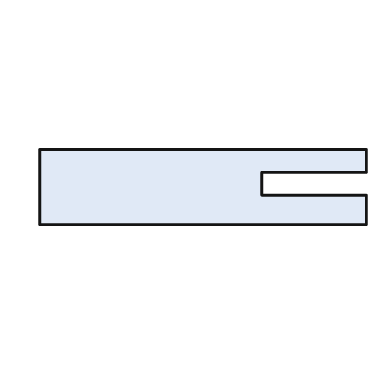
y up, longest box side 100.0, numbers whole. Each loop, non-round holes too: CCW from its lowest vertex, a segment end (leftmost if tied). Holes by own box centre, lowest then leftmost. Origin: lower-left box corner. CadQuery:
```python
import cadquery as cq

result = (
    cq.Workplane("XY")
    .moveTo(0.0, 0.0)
    .lineTo(100.0, 0.0)
    .lineTo(100.0, 9.0)
    .lineTo(68.0, 9.0)
    .lineTo(68.0, 16.0)
    .lineTo(100.0, 16.0)
    .lineTo(100.0, 23.0)
    .lineTo(0.0, 23.0)
    .close()
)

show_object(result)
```